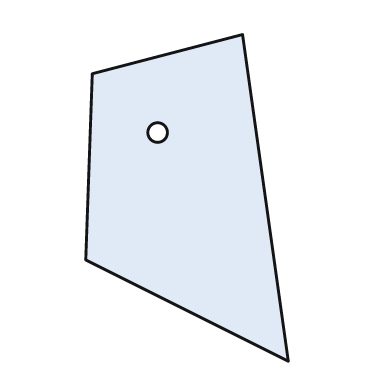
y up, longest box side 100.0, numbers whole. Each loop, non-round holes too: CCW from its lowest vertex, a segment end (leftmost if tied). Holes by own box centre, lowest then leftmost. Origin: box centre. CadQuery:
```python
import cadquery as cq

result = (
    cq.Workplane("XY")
    .moveTo(31.0, -50.0)
    .lineTo(17.0, 50.0)
    .lineTo(-29.0, 38.0)
    .lineTo(-31.0, -19.0)
    .close()
    .moveTo(-9.0, 20.0)
    .circle(3.0)
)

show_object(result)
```